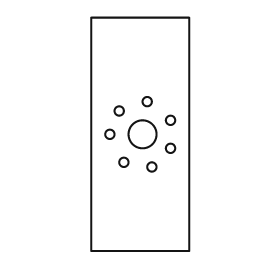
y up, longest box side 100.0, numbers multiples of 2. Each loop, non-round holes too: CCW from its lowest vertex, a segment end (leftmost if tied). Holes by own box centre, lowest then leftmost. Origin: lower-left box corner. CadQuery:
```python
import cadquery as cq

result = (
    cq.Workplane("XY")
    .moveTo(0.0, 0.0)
    .lineTo(42.0, 0.0)
    .lineTo(42.0, 100.0)
    .lineTo(0.0, 100.0)
    .close()
    .moveTo(26.0, 36.0)
    .circle(2.0)
    .moveTo(14.0, 38.0)
    .circle(2.0)
    .moveTo(34.0, 44.0)
    .circle(2.0)
    .moveTo(8.0, 50.0)
    .circle(2.0)
    .moveTo(22.0, 50.0)
    .circle(6.0)
    .moveTo(34.0, 56.0)
    .circle(2.0)
    .moveTo(12.0, 60.0)
    .circle(2.0)
    .moveTo(24.0, 64.0)
    .circle(2.0)
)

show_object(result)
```